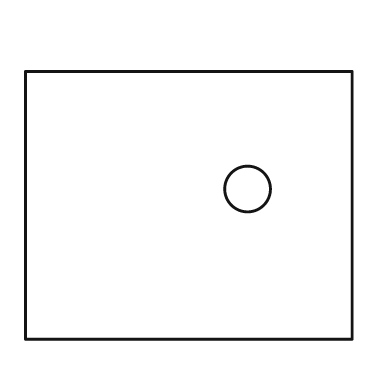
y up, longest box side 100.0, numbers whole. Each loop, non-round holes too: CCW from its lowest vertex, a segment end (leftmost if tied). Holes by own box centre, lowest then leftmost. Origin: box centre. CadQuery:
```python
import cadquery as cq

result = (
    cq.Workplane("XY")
    .moveTo(-50.0, -41.0)
    .lineTo(50.0, -41.0)
    .lineTo(50.0, 41.0)
    .lineTo(-50.0, 41.0)
    .close()
    .moveTo(18.0, 5.0)
    .circle(7.0)
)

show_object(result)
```